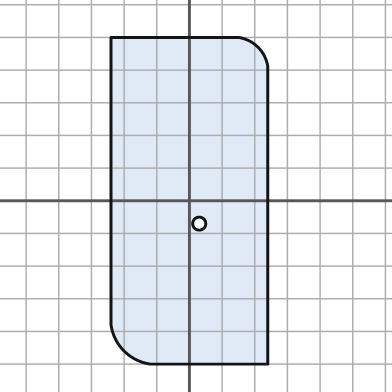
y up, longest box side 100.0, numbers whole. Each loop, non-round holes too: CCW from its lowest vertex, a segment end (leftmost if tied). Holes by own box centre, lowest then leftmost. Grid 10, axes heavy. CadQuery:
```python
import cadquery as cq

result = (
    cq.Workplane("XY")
    .moveTo(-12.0, -50.0)
    .lineTo(24.0, -50.0)
    .lineTo(24.0, 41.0)
    .threePointArc((21.0, 47.0), (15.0, 50.0))
    .lineTo(-24.0, 50.0)
    .lineTo(-24.0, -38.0)
    .threePointArc((-20.0, -46.0), (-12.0, -50.0))
    .close()
    .moveTo(3.0, -7.0)
    .circle(2.0)
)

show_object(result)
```